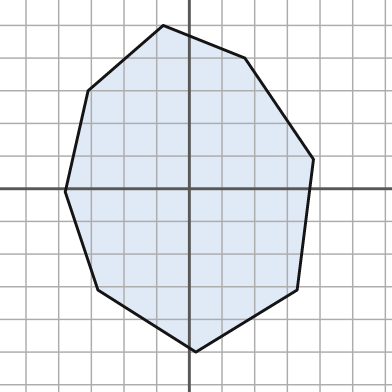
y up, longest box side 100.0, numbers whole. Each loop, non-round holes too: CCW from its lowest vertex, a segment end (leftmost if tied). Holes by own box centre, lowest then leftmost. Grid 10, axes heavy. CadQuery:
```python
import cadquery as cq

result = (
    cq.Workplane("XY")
    .moveTo(2.0, -50.0)
    .lineTo(33.0, -31.0)
    .lineTo(38.0, 9.0)
    .lineTo(17.0, 40.0)
    .lineTo(-8.0, 50.0)
    .lineTo(-31.0, 30.0)
    .lineTo(-38.0, -1.0)
    .lineTo(-28.0, -31.0)
    .close()
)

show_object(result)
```